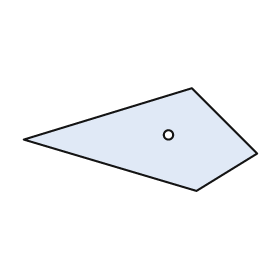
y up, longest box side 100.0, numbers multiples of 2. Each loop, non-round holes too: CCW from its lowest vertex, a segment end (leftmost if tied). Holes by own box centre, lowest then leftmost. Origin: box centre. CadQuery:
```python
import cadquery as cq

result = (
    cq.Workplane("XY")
    .moveTo(24.0, -22.0)
    .lineTo(50.0, -6.0)
    .lineTo(22.0, 22.0)
    .lineTo(-50.0, 0.0)
    .close()
    .moveTo(12.0, 2.0)
    .circle(2.0)
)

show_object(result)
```